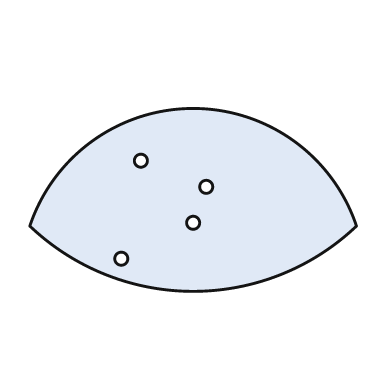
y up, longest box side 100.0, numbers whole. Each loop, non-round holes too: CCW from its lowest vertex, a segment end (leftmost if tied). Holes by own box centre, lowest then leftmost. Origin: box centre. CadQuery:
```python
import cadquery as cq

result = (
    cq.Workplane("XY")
    .moveTo(-50.0, -8.0)
    .threePointArc((0.0, -28.0), (50.0, -8.0))
    .threePointArc((0.0, 28.0), (-50.0, -8.0))
    .close()
    .moveTo(-22.0, -18.0)
    .circle(2.0)
    .moveTo(0.0, -7.0)
    .circle(2.0)
    .moveTo(4.0, 4.0)
    .circle(2.0)
    .moveTo(-16.0, 12.0)
    .circle(2.0)
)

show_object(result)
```